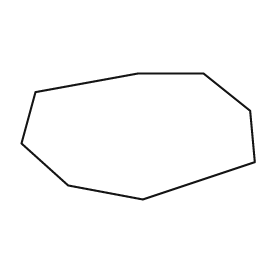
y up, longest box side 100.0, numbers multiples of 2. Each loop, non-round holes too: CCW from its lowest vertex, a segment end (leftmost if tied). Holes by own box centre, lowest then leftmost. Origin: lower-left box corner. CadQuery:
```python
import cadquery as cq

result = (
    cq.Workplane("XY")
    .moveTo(52.0, 0.0)
    .lineTo(100.0, 16.0)
    .lineTo(98.0, 38.0)
    .lineTo(78.0, 54.0)
    .lineTo(50.0, 54.0)
    .lineTo(6.0, 46.0)
    .lineTo(0.0, 24.0)
    .lineTo(20.0, 6.0)
    .close()
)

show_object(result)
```